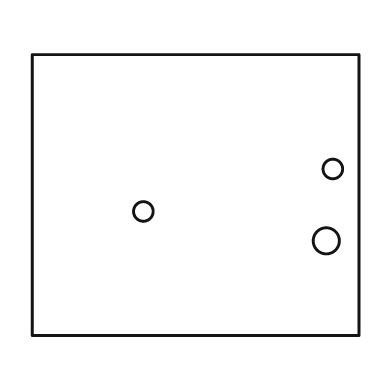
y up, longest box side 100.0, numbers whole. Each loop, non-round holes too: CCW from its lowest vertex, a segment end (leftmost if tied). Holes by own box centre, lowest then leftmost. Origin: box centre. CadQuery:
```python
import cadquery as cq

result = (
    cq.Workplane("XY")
    .moveTo(-50.0, -43.0)
    .lineTo(50.0, -43.0)
    .lineTo(50.0, 43.0)
    .lineTo(-50.0, 43.0)
    .close()
    .moveTo(40.0, -14.0)
    .circle(4.0)
    .moveTo(-16.0, -5.0)
    .circle(3.0)
    .moveTo(42.0, 8.0)
    .circle(3.0)
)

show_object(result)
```